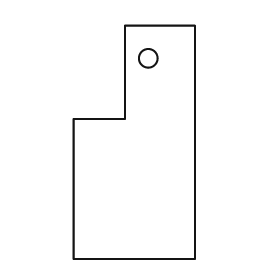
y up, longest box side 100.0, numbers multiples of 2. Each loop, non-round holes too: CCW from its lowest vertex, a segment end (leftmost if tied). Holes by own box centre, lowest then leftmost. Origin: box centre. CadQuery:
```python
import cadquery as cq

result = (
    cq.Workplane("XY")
    .moveTo(-26.0, -50.0)
    .lineTo(26.0, -50.0)
    .lineTo(26.0, 50.0)
    .lineTo(-4.0, 50.0)
    .lineTo(-4.0, 10.0)
    .lineTo(-26.0, 10.0)
    .close()
    .moveTo(6.0, 36.0)
    .circle(4.0)
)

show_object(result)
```